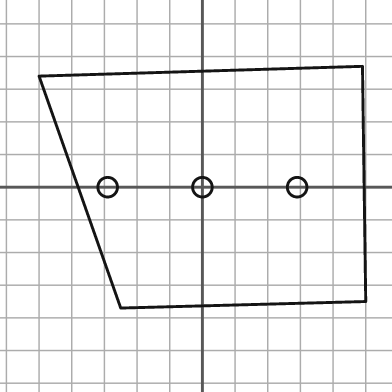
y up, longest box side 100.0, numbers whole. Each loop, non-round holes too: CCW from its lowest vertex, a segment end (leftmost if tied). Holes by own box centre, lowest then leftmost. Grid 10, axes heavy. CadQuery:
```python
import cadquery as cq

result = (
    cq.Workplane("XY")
    .moveTo(-25.0, -37.0)
    .lineTo(50.0, -35.0)
    .lineTo(49.0, 37.0)
    .lineTo(-50.0, 34.0)
    .close()
    .moveTo(-29.0, 0.0)
    .circle(3.0)
    .moveTo(0.0, 0.0)
    .circle(3.0)
    .moveTo(29.0, 0.0)
    .circle(3.0)
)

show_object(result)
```